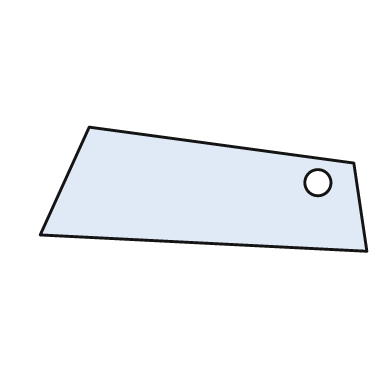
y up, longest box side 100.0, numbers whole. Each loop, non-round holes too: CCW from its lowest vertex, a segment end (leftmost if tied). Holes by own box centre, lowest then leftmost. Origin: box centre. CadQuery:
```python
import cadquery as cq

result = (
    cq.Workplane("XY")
    .moveTo(50.0, -19.0)
    .lineTo(46.0, 8.0)
    .lineTo(-35.0, 19.0)
    .lineTo(-50.0, -14.0)
    .close()
    .moveTo(35.0, 2.0)
    .circle(4.0)
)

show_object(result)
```